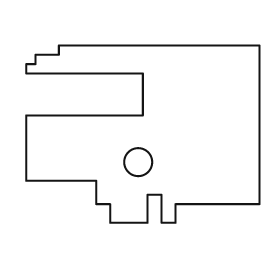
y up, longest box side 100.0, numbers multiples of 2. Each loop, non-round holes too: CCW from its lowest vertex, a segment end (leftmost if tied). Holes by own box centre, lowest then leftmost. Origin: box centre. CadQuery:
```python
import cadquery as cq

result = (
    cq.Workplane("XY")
    .moveTo(-14.0, -38.0)
    .lineTo(2.0, -38.0)
    .lineTo(2.0, -26.0)
    .lineTo(8.0, -26.0)
    .lineTo(8.0, -38.0)
    .lineTo(14.0, -38.0)
    .lineTo(14.0, -30.0)
    .lineTo(50.0, -30.0)
    .lineTo(50.0, 38.0)
    .lineTo(-36.0, 38.0)
    .lineTo(-36.0, 34.0)
    .lineTo(-46.0, 34.0)
    .lineTo(-46.0, 30.0)
    .lineTo(-50.0, 30.0)
    .lineTo(-50.0, 26.0)
    .lineTo(0.0, 26.0)
    .lineTo(0.0, 8.0)
    .lineTo(-50.0, 8.0)
    .lineTo(-50.0, -20.0)
    .lineTo(-20.0, -20.0)
    .lineTo(-20.0, -30.0)
    .lineTo(-14.0, -30.0)
    .close()
    .moveTo(-2.0, -12.0)
    .circle(6.0)
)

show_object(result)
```